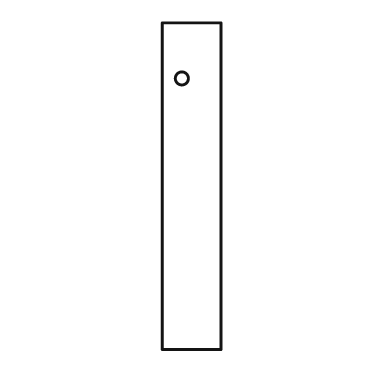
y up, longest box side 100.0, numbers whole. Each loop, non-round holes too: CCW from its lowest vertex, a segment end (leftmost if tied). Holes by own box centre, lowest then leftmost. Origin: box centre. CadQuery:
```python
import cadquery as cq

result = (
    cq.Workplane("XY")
    .moveTo(-9.0, -50.0)
    .lineTo(9.0, -50.0)
    .lineTo(9.0, 50.0)
    .lineTo(-9.0, 50.0)
    .close()
    .moveTo(-3.0, 33.0)
    .circle(2.0)
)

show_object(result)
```